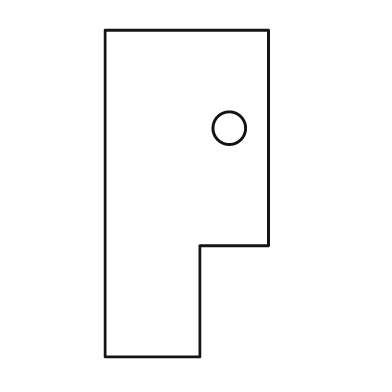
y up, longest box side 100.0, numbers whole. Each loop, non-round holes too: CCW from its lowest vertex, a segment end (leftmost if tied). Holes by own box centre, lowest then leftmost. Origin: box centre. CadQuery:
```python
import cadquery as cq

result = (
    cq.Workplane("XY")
    .moveTo(-25.0, -50.0)
    .lineTo(4.0, -50.0)
    .lineTo(4.0, -16.0)
    .lineTo(25.0, -16.0)
    .lineTo(25.0, 50.0)
    .lineTo(-25.0, 50.0)
    .close()
    .moveTo(13.0, 20.0)
    .circle(5.0)
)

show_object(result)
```